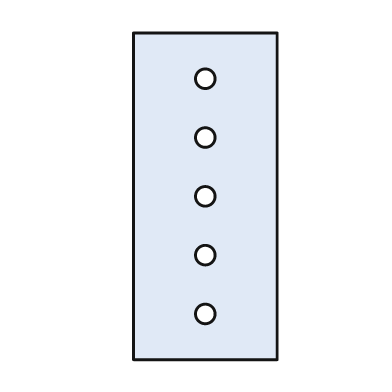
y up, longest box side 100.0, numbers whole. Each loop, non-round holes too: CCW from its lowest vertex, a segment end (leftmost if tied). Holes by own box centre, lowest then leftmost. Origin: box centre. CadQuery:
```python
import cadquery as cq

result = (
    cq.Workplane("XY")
    .moveTo(-22.0, -50.0)
    .lineTo(22.0, -50.0)
    .lineTo(22.0, 50.0)
    .lineTo(-22.0, 50.0)
    .close()
    .moveTo(0.0, -36.0)
    .circle(3.0)
    .moveTo(0.0, -18.0)
    .circle(3.0)
    .moveTo(0.0, 0.0)
    .circle(3.0)
    .moveTo(0.0, 18.0)
    .circle(3.0)
    .moveTo(0.0, 36.0)
    .circle(3.0)
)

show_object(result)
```